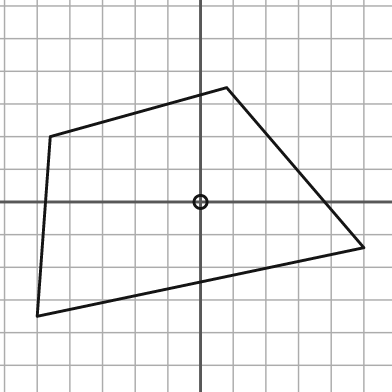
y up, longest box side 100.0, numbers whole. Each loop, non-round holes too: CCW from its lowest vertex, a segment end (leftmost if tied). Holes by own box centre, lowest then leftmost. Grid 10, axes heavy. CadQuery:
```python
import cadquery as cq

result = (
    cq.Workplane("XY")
    .moveTo(-50.0, -35.0)
    .lineTo(50.0, -14.0)
    .lineTo(8.0, 35.0)
    .lineTo(-46.0, 20.0)
    .close()
    .moveTo(0.0, 0.0)
    .circle(2.0)
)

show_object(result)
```